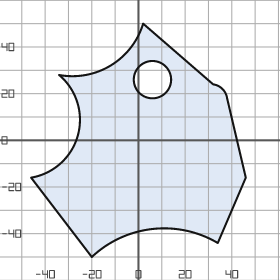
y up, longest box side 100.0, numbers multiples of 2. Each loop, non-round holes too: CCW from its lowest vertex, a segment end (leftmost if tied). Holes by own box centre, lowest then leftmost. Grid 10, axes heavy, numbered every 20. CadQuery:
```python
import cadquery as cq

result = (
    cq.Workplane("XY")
    .moveTo(-20.0, -50.0)
    .threePointArc((6.0, -38.0), (34.0, -44.0))
    .lineTo(46.0, -16.0)
    .lineTo(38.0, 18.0)
    .threePointArc((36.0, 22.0), (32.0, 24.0))
    .lineTo(2.0, 50.0)
    .threePointArc((-12.0, 32.0), (-34.0, 28.0))
    .threePointArc((-26.0, 2.0), (-46.0, -16.0))
    .close()
    .moveTo(6.0, 26.0)
    .circle(8.0)
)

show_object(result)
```